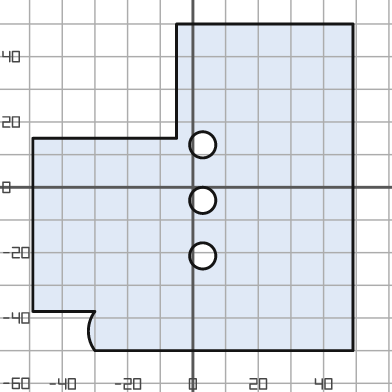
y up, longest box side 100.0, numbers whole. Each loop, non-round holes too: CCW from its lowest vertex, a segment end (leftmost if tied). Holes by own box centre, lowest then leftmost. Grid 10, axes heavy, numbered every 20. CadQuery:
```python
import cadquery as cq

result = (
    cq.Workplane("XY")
    .moveTo(-30.0, -50.0)
    .lineTo(49.0, -50.0)
    .lineTo(49.0, 50.0)
    .lineTo(-5.0, 50.0)
    .lineTo(-5.0, 15.0)
    .lineTo(-49.0, 15.0)
    .lineTo(-49.0, -38.0)
    .lineTo(-30.0, -38.0)
    .threePointArc((-32.0, -44.0), (-30.0, -50.0))
    .close()
    .moveTo(3.0, -21.0)
    .circle(4.0)
    .moveTo(3.0, -4.0)
    .circle(4.0)
    .moveTo(3.0, 13.0)
    .circle(4.0)
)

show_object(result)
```